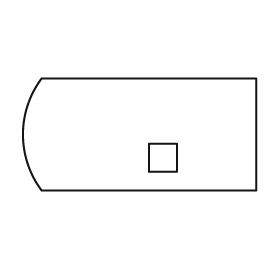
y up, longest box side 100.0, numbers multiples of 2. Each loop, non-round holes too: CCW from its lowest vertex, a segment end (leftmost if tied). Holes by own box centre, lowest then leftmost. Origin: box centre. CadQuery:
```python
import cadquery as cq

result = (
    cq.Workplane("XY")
    .moveTo(-42.0, -24.0)
    .lineTo(50.0, -24.0)
    .lineTo(50.0, 24.0)
    .lineTo(-42.0, 24.0)
    .threePointArc((-50.0, 0.0), (-42.0, -24.0))
    .close()
    .moveTo(4.0, -16.0)
    .lineTo(16.0, -16.0)
    .lineTo(16.0, -4.0)
    .lineTo(4.0, -4.0)
    .close()
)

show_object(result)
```